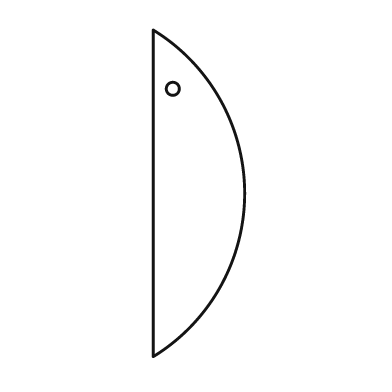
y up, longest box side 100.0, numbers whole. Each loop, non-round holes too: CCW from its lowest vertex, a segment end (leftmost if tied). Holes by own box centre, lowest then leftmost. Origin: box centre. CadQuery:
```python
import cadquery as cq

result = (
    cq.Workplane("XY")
    .moveTo(-14.0, -50.0)
    .threePointArc((14.0, 0.0), (-14.0, 50.0))
    .close()
    .moveTo(-8.0, 32.0)
    .circle(2.0)
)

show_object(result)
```